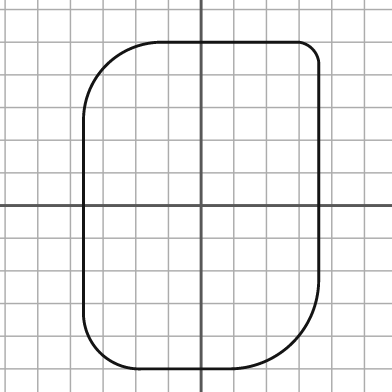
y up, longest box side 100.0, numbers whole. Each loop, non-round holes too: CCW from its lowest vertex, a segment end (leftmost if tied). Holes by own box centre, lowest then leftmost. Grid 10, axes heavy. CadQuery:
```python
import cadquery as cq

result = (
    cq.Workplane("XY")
    .moveTo(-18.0, -50.0)
    .lineTo(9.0, -50.0)
    .threePointArc((28.0, -42.0), (36.0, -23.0))
    .lineTo(36.0, 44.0)
    .threePointArc((34.0, 48.0), (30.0, 50.0))
    .lineTo(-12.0, 50.0)
    .threePointArc((-29.0, 43.0), (-36.0, 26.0))
    .lineTo(-36.0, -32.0)
    .threePointArc((-31.0, -45.0), (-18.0, -50.0))
    .close()
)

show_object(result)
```